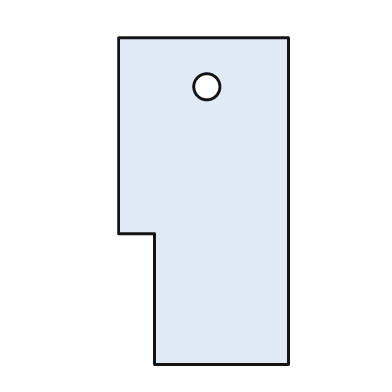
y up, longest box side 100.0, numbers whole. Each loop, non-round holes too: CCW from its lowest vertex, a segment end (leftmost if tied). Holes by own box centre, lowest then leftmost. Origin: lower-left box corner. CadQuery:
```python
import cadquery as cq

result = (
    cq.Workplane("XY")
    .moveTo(11.0, 0.0)
    .lineTo(52.0, 0.0)
    .lineTo(52.0, 100.0)
    .lineTo(0.0, 100.0)
    .lineTo(0.0, 40.0)
    .lineTo(11.0, 40.0)
    .close()
    .moveTo(27.0, 85.0)
    .circle(4.0)
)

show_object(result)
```